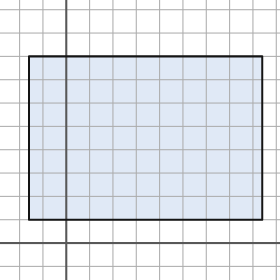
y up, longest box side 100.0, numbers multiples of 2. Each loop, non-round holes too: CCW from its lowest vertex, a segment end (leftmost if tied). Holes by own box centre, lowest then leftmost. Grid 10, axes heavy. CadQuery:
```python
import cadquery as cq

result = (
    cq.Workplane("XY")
    .moveTo(-16.0, 10.0)
    .lineTo(84.0, 10.0)
    .lineTo(84.0, 80.0)
    .lineTo(-16.0, 80.0)
    .close()
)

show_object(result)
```